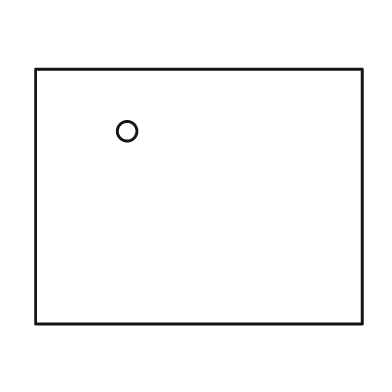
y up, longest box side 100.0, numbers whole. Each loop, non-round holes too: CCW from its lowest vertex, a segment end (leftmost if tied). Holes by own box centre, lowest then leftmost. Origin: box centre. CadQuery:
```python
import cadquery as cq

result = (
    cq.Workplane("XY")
    .moveTo(-50.0, -39.0)
    .lineTo(50.0, -39.0)
    .lineTo(50.0, 39.0)
    .lineTo(-50.0, 39.0)
    .close()
    .moveTo(-22.0, 20.0)
    .circle(3.0)
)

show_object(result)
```